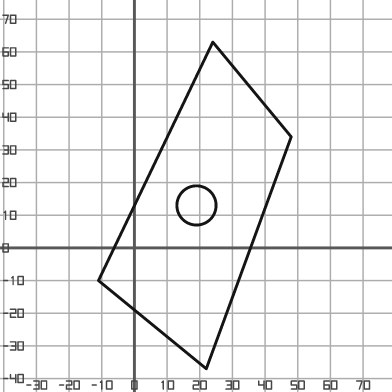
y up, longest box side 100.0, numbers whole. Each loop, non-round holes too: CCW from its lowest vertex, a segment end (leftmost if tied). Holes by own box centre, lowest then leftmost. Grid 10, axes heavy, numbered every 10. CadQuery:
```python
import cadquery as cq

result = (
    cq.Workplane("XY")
    .moveTo(22.0, -37.0)
    .lineTo(48.0, 34.0)
    .lineTo(24.0, 63.0)
    .lineTo(-11.0, -10.0)
    .close()
    .moveTo(19.0, 13.0)
    .circle(6.0)
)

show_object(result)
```